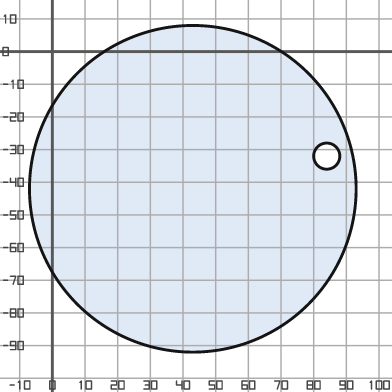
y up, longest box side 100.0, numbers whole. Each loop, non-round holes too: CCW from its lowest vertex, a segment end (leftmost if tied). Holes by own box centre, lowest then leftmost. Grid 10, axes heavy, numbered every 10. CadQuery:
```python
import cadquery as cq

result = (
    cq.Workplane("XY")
    .moveTo(43.0, -42.0)
    .circle(50.0)
    .moveTo(84.0, -32.0)
    .circle(4.0)
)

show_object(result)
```